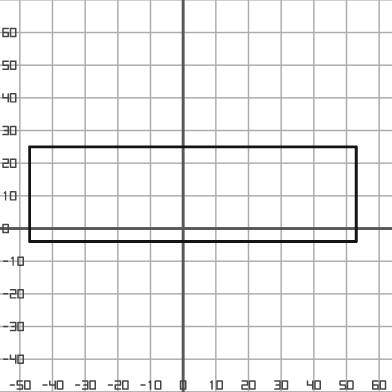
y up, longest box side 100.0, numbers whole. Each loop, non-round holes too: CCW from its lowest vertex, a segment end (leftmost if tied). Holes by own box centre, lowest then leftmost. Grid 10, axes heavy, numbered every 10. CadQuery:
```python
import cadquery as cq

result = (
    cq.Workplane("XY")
    .moveTo(-47.0, -4.0)
    .lineTo(53.0, -4.0)
    .lineTo(53.0, 25.0)
    .lineTo(-47.0, 25.0)
    .close()
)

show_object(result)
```